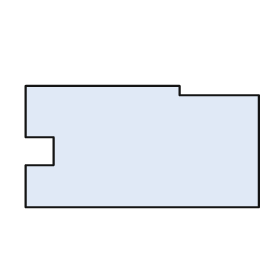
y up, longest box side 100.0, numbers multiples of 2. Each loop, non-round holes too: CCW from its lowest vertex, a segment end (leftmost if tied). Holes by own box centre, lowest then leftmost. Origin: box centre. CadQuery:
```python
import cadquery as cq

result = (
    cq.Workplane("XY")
    .moveTo(-50.0, -26.0)
    .lineTo(50.0, -26.0)
    .lineTo(50.0, 22.0)
    .lineTo(16.0, 22.0)
    .lineTo(16.0, 26.0)
    .lineTo(-50.0, 26.0)
    .lineTo(-50.0, 4.0)
    .lineTo(-38.0, 4.0)
    .lineTo(-38.0, -8.0)
    .lineTo(-50.0, -8.0)
    .close()
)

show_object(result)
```